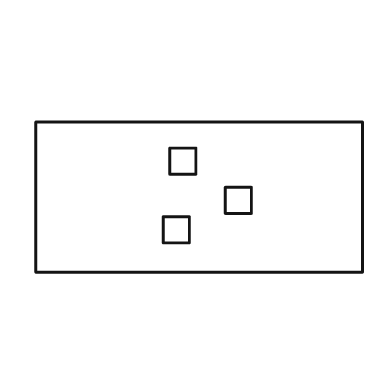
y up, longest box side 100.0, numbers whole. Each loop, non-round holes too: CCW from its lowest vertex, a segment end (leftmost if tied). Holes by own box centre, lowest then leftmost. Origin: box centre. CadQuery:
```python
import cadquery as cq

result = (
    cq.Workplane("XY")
    .moveTo(-50.0, -23.0)
    .lineTo(50.0, -23.0)
    .lineTo(50.0, 23.0)
    .lineTo(-50.0, 23.0)
    .close()
    .moveTo(-11.0, -14.0)
    .lineTo(-3.0, -14.0)
    .lineTo(-3.0, -6.0)
    .lineTo(-11.0, -6.0)
    .close()
    .moveTo(8.0, -5.0)
    .lineTo(16.0, -5.0)
    .lineTo(16.0, 3.0)
    .lineTo(8.0, 3.0)
    .close()
    .moveTo(-9.0, 7.0)
    .lineTo(-1.0, 7.0)
    .lineTo(-1.0, 15.0)
    .lineTo(-9.0, 15.0)
    .close()
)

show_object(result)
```